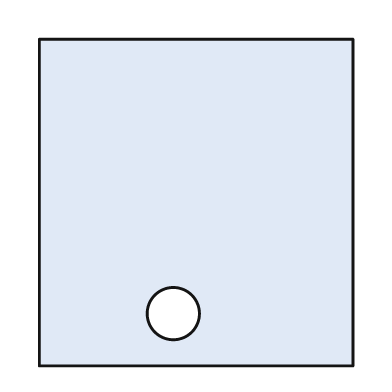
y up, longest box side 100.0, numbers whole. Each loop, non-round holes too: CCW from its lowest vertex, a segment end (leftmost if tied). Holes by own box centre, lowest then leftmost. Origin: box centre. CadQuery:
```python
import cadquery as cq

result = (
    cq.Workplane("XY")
    .moveTo(-48.0, -50.0)
    .lineTo(48.0, -50.0)
    .lineTo(48.0, 50.0)
    .lineTo(-48.0, 50.0)
    .close()
    .moveTo(-7.0, -34.0)
    .circle(8.0)
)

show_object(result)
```